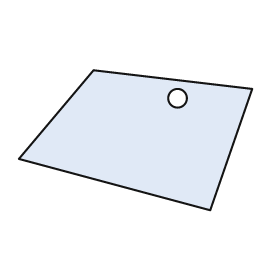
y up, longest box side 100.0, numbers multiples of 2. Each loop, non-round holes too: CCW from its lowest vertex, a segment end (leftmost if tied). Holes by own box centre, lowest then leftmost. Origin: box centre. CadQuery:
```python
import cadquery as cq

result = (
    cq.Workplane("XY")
    .moveTo(32.0, -30.0)
    .lineTo(50.0, 22.0)
    .lineTo(-18.0, 30.0)
    .lineTo(-50.0, -8.0)
    .close()
    .moveTo(18.0, 18.0)
    .circle(4.0)
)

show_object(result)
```